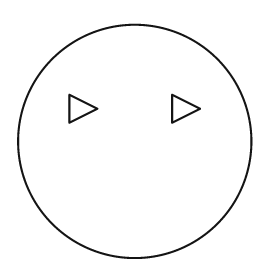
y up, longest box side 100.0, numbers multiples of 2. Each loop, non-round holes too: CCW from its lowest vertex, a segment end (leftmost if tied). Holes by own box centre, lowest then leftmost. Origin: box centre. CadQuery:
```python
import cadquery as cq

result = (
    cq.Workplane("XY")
    .moveTo(0.0, 0.0)
    .circle(50.0)
    .moveTo(-28.0, 8.0)
    .lineTo(-16.0, 14.0)
    .lineTo(-28.0, 20.0)
    .close()
    .moveTo(16.0, 8.0)
    .lineTo(28.0, 14.0)
    .lineTo(16.0, 20.0)
    .close()
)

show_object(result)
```